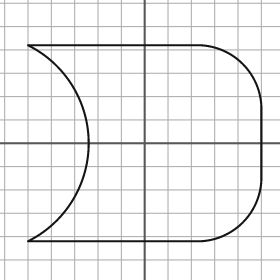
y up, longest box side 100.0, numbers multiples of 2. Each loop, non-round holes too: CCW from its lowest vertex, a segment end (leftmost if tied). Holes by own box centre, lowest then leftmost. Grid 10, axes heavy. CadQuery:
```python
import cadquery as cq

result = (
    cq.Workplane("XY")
    .moveTo(-50.0, -42.0)
    .lineTo(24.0, -42.0)
    .threePointArc((42.0, -34.0), (50.0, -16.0))
    .lineTo(50.0, 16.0)
    .threePointArc((42.0, 34.0), (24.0, 42.0))
    .lineTo(-50.0, 42.0)
    .threePointArc((-24.0, 0.0), (-50.0, -42.0))
    .close()
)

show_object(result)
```